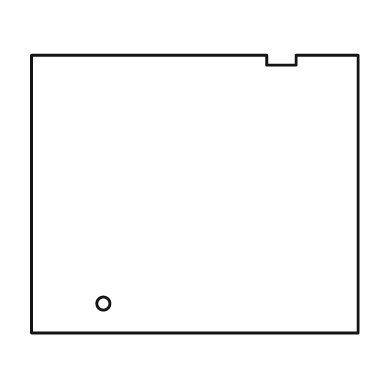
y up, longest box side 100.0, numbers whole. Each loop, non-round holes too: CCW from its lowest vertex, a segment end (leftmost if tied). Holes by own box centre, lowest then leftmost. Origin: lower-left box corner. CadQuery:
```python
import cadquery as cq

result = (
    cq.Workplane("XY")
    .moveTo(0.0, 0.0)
    .lineTo(100.0, 0.0)
    .lineTo(100.0, 85.0)
    .lineTo(81.0, 85.0)
    .lineTo(81.0, 82.0)
    .lineTo(72.0, 82.0)
    .lineTo(72.0, 85.0)
    .lineTo(0.0, 85.0)
    .close()
    .moveTo(22.0, 9.0)
    .circle(2.0)
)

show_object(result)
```